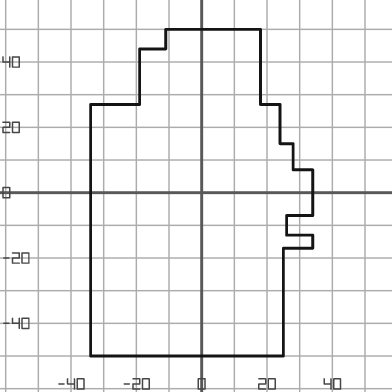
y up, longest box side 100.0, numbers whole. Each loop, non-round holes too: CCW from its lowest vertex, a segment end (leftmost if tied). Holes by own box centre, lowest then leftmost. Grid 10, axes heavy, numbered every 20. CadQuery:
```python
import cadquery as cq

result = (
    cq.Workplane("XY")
    .moveTo(-34.0, -50.0)
    .lineTo(25.0, -50.0)
    .lineTo(25.0, -17.0)
    .lineTo(34.0, -17.0)
    .lineTo(34.0, -13.0)
    .lineTo(26.0, -13.0)
    .lineTo(26.0, -7.0)
    .lineTo(34.0, -7.0)
    .lineTo(34.0, 7.0)
    .lineTo(28.0, 7.0)
    .lineTo(28.0, 15.0)
    .lineTo(24.0, 15.0)
    .lineTo(24.0, 27.0)
    .lineTo(18.0, 27.0)
    .lineTo(18.0, 50.0)
    .lineTo(-11.0, 50.0)
    .lineTo(-11.0, 44.0)
    .lineTo(-19.0, 44.0)
    .lineTo(-19.0, 27.0)
    .lineTo(-34.0, 27.0)
    .close()
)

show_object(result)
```